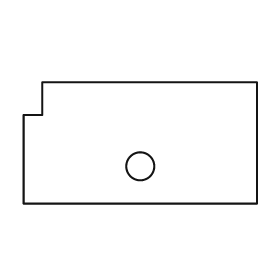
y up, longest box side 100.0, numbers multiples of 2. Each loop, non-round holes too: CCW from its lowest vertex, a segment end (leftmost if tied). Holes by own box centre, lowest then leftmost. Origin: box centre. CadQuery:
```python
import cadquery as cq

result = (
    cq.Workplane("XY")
    .moveTo(-50.0, -26.0)
    .lineTo(50.0, -26.0)
    .lineTo(50.0, 26.0)
    .lineTo(-42.0, 26.0)
    .lineTo(-42.0, 12.0)
    .lineTo(-50.0, 12.0)
    .close()
    .moveTo(0.0, -10.0)
    .circle(6.0)
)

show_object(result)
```